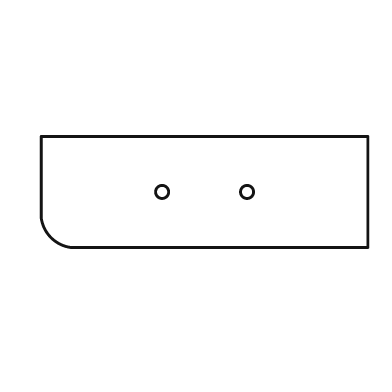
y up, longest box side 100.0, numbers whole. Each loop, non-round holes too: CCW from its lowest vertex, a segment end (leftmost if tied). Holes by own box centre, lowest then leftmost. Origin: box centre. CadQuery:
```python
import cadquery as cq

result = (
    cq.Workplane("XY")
    .moveTo(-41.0, -17.0)
    .lineTo(50.0, -17.0)
    .lineTo(50.0, 17.0)
    .lineTo(-50.0, 17.0)
    .lineTo(-50.0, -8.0)
    .threePointArc((-47.0, -14.0), (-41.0, -17.0))
    .close()
    .moveTo(-13.0, 0.0)
    .circle(2.0)
    .moveTo(13.0, 0.0)
    .circle(2.0)
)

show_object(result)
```